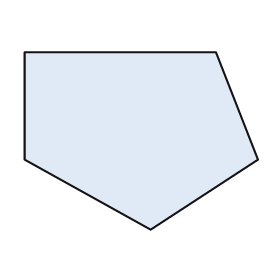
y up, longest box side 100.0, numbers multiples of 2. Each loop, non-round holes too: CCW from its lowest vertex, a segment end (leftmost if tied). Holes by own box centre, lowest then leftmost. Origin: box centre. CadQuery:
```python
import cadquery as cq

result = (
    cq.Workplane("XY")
    .moveTo(4.0, -38.0)
    .lineTo(50.0, -8.0)
    .lineTo(32.0, 38.0)
    .lineTo(-50.0, 38.0)
    .lineTo(-50.0, -8.0)
    .close()
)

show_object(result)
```